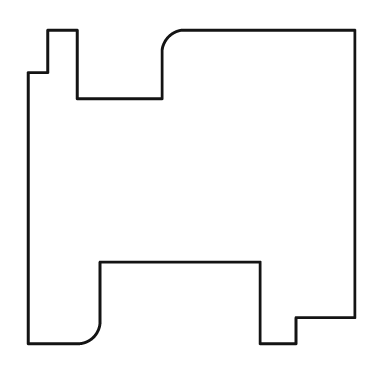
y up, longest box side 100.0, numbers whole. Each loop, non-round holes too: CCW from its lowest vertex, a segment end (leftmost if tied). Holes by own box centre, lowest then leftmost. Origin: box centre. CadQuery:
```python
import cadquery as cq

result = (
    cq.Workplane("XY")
    .moveTo(-50.0, -48.0)
    .lineTo(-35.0, -48.0)
    .threePointArc((-30.0, -46.0), (-28.0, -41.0))
    .lineTo(-28.0, -23.0)
    .lineTo(21.0, -23.0)
    .lineTo(21.0, -48.0)
    .lineTo(32.0, -48.0)
    .lineTo(32.0, -40.0)
    .lineTo(50.0, -40.0)
    .lineTo(50.0, 48.0)
    .lineTo(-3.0, 48.0)
    .threePointArc((-7.0, 46.0), (-9.0, 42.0))
    .lineTo(-9.0, 27.0)
    .lineTo(-35.0, 27.0)
    .lineTo(-35.0, 48.0)
    .lineTo(-44.0, 48.0)
    .lineTo(-44.0, 35.0)
    .lineTo(-50.0, 35.0)
    .close()
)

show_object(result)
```